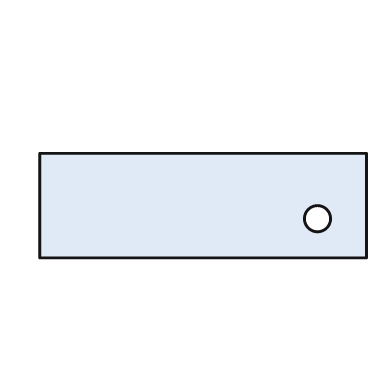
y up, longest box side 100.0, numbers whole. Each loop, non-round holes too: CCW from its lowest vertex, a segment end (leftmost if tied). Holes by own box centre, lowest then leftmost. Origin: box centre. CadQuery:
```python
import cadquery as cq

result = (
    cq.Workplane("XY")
    .moveTo(-50.0, -16.0)
    .lineTo(50.0, -16.0)
    .lineTo(50.0, 16.0)
    .lineTo(-50.0, 16.0)
    .close()
    .moveTo(35.0, -4.0)
    .circle(4.0)
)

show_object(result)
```